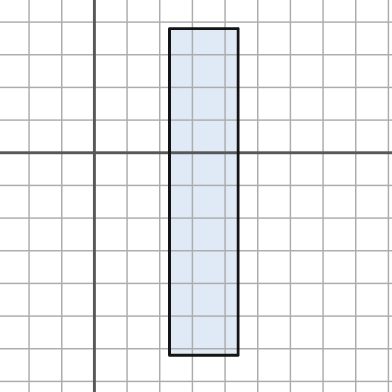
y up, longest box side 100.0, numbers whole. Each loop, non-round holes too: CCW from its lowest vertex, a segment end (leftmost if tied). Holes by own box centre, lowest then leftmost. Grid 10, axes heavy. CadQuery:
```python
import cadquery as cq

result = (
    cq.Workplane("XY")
    .moveTo(23.0, -62.0)
    .lineTo(44.0, -62.0)
    .lineTo(44.0, 38.0)
    .lineTo(23.0, 38.0)
    .close()
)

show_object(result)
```